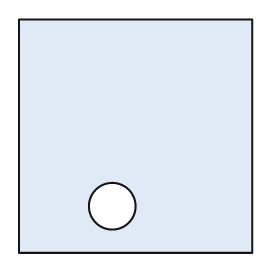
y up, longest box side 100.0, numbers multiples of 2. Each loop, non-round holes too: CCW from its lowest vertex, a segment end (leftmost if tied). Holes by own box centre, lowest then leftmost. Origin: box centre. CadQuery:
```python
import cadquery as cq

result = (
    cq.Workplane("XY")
    .moveTo(-50.0, -50.0)
    .lineTo(50.0, -50.0)
    .lineTo(50.0, 50.0)
    .lineTo(-50.0, 50.0)
    .close()
    .moveTo(-10.0, -30.0)
    .circle(10.0)
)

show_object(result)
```